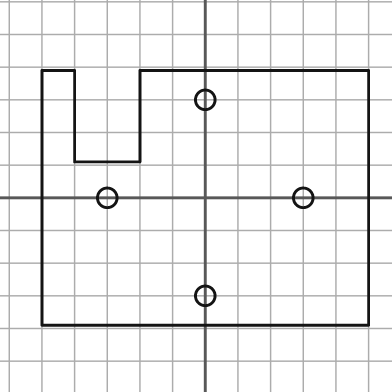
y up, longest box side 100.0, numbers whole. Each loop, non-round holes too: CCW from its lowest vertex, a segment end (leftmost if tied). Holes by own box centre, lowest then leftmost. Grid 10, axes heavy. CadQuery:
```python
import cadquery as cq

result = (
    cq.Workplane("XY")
    .moveTo(-50.0, -39.0)
    .lineTo(50.0, -39.0)
    .lineTo(50.0, 39.0)
    .lineTo(-20.0, 39.0)
    .lineTo(-20.0, 11.0)
    .lineTo(-40.0, 11.0)
    .lineTo(-40.0, 39.0)
    .lineTo(-50.0, 39.0)
    .close()
    .moveTo(0.0, -30.0)
    .circle(3.0)
    .moveTo(-30.0, 0.0)
    .circle(3.0)
    .moveTo(30.0, 0.0)
    .circle(3.0)
    .moveTo(0.0, 30.0)
    .circle(3.0)
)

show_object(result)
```